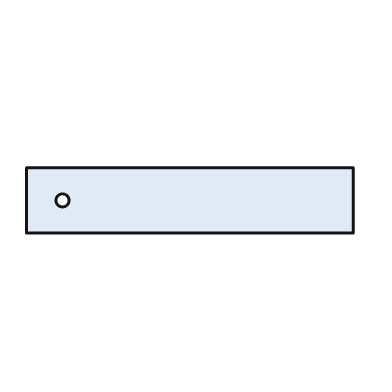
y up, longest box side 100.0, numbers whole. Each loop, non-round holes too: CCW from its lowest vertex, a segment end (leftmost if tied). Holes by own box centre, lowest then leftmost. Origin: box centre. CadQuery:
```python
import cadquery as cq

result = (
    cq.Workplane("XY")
    .moveTo(-50.0, -10.0)
    .lineTo(50.0, -10.0)
    .lineTo(50.0, 10.0)
    .lineTo(-50.0, 10.0)
    .close()
    .moveTo(-39.0, 0.0)
    .circle(2.0)
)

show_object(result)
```